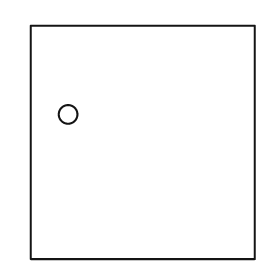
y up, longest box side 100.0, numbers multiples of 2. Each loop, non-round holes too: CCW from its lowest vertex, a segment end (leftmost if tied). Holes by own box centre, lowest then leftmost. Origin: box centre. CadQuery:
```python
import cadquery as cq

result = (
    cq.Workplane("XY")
    .moveTo(-48.0, -50.0)
    .lineTo(48.0, -50.0)
    .lineTo(48.0, 50.0)
    .lineTo(-48.0, 50.0)
    .close()
    .moveTo(-32.0, 12.0)
    .circle(4.0)
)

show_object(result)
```